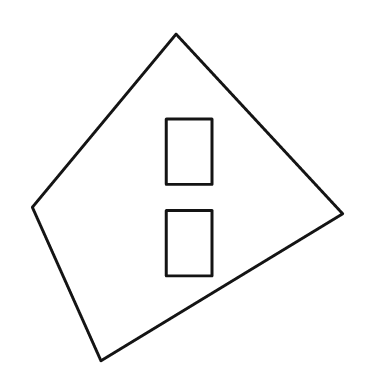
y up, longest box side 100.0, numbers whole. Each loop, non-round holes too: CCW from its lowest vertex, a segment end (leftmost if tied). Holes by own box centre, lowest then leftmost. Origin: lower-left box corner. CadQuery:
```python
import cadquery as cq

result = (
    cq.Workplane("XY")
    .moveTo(21.0, 0.0)
    .lineTo(95.0, 45.0)
    .lineTo(44.0, 100.0)
    .lineTo(0.0, 47.0)
    .close()
    .moveTo(41.0, 26.0)
    .lineTo(55.0, 26.0)
    .lineTo(55.0, 46.0)
    .lineTo(41.0, 46.0)
    .close()
    .moveTo(41.0, 54.0)
    .lineTo(55.0, 54.0)
    .lineTo(55.0, 74.0)
    .lineTo(41.0, 74.0)
    .close()
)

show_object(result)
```